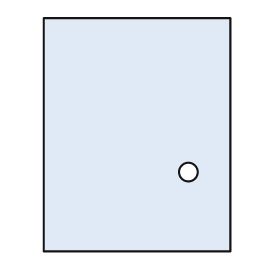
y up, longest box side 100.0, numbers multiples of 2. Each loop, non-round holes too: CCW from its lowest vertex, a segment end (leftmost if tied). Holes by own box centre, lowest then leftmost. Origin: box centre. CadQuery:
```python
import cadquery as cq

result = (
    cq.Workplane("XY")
    .moveTo(-40.0, -50.0)
    .lineTo(40.0, -50.0)
    .lineTo(40.0, 50.0)
    .lineTo(-40.0, 50.0)
    .close()
    .moveTo(22.0, -16.0)
    .circle(4.0)
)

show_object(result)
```